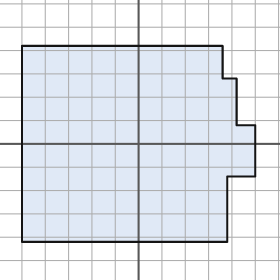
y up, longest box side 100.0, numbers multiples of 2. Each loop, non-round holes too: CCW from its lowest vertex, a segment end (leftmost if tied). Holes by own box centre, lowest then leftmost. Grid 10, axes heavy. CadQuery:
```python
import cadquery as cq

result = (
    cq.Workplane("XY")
    .moveTo(-50.0, -42.0)
    .lineTo(38.0, -42.0)
    .lineTo(38.0, -14.0)
    .lineTo(50.0, -14.0)
    .lineTo(50.0, 8.0)
    .lineTo(42.0, 8.0)
    .lineTo(42.0, 28.0)
    .lineTo(36.0, 28.0)
    .lineTo(36.0, 42.0)
    .lineTo(-50.0, 42.0)
    .close()
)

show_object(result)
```